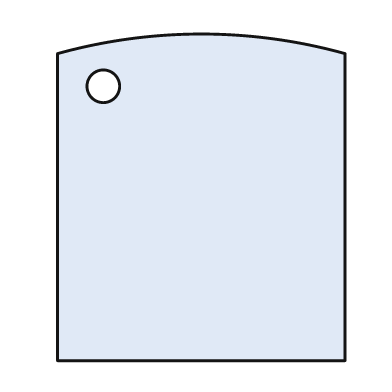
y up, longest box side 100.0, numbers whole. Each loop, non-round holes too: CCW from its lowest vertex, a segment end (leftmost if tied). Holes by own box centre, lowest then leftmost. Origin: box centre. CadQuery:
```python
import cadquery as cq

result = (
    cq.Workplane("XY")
    .moveTo(-44.0, -50.0)
    .lineTo(44.0, -50.0)
    .lineTo(44.0, 44.0)
    .threePointArc((0.0, 50.0), (-44.0, 44.0))
    .close()
    .moveTo(-30.0, 34.0)
    .circle(5.0)
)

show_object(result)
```